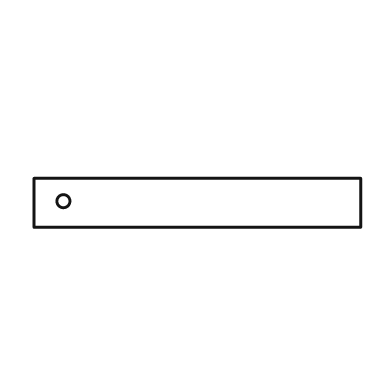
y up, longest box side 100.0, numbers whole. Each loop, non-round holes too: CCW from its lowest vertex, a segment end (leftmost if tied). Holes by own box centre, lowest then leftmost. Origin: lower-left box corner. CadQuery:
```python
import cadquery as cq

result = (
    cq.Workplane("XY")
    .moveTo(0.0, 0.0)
    .lineTo(100.0, 0.0)
    .lineTo(100.0, 15.0)
    .lineTo(0.0, 15.0)
    .close()
    .moveTo(9.0, 8.0)
    .circle(2.0)
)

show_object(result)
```